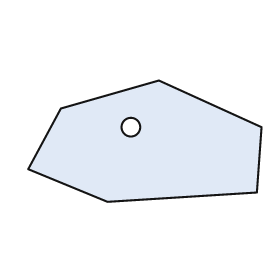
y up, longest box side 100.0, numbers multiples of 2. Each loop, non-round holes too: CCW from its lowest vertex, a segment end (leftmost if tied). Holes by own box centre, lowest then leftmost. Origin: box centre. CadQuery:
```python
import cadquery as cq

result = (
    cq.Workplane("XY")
    .moveTo(-16.0, -26.0)
    .lineTo(48.0, -22.0)
    .lineTo(50.0, 6.0)
    .lineTo(6.0, 26.0)
    .lineTo(-36.0, 14.0)
    .lineTo(-50.0, -12.0)
    .close()
    .moveTo(-6.0, 6.0)
    .circle(4.0)
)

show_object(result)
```